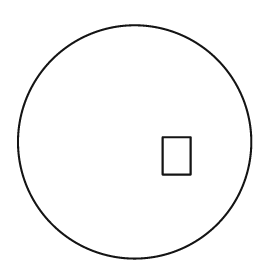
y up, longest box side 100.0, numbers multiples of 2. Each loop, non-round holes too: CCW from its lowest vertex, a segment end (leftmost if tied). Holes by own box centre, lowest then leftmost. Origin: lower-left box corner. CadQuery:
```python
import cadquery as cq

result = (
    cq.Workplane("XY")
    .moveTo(50.0, 50.0)
    .circle(50.0)
    .moveTo(62.0, 36.0)
    .lineTo(74.0, 36.0)
    .lineTo(74.0, 52.0)
    .lineTo(62.0, 52.0)
    .close()
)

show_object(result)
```